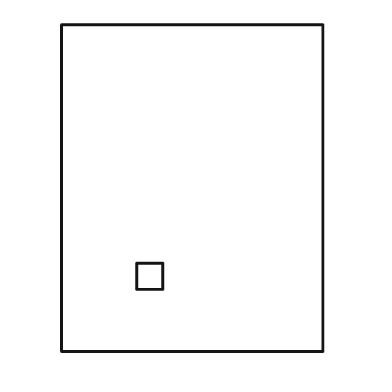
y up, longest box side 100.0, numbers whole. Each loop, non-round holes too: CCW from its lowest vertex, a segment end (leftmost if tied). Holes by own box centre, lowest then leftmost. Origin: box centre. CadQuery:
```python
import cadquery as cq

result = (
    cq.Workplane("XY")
    .moveTo(-40.0, -50.0)
    .lineTo(40.0, -50.0)
    .lineTo(40.0, 50.0)
    .lineTo(-40.0, 50.0)
    .close()
    .moveTo(-17.0, -31.0)
    .lineTo(-9.0, -31.0)
    .lineTo(-9.0, -23.0)
    .lineTo(-17.0, -23.0)
    .close()
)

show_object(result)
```